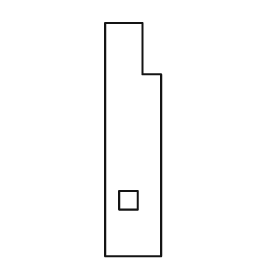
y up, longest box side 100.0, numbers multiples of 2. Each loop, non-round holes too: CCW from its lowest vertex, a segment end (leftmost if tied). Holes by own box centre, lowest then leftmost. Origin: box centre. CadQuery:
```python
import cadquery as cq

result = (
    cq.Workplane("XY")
    .moveTo(-12.0, -50.0)
    .lineTo(12.0, -50.0)
    .lineTo(12.0, 28.0)
    .lineTo(4.0, 28.0)
    .lineTo(4.0, 50.0)
    .lineTo(-12.0, 50.0)
    .close()
    .moveTo(-6.0, -30.0)
    .lineTo(2.0, -30.0)
    .lineTo(2.0, -22.0)
    .lineTo(-6.0, -22.0)
    .close()
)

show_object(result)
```